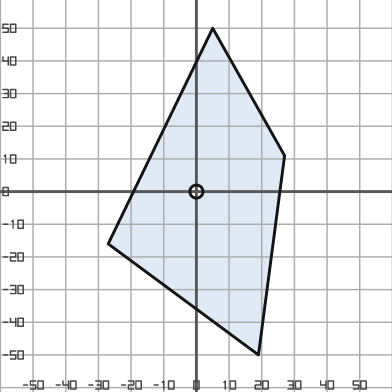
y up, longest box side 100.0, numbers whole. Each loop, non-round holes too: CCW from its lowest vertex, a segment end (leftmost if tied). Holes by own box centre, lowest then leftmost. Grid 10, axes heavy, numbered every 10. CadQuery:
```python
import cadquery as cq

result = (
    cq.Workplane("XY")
    .moveTo(19.0, -50.0)
    .lineTo(27.0, 11.0)
    .lineTo(5.0, 50.0)
    .lineTo(-27.0, -16.0)
    .close()
    .moveTo(0.0, 0.0)
    .circle(2.0)
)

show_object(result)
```